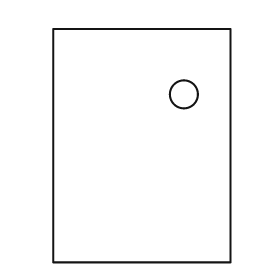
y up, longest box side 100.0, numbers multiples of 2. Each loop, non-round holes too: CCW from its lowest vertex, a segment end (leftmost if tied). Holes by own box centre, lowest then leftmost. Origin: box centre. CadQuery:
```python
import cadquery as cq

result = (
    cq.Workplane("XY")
    .moveTo(-38.0, -50.0)
    .lineTo(38.0, -50.0)
    .lineTo(38.0, 50.0)
    .lineTo(-38.0, 50.0)
    .close()
    .moveTo(18.0, 22.0)
    .circle(6.0)
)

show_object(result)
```